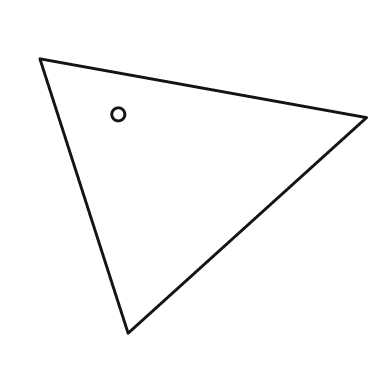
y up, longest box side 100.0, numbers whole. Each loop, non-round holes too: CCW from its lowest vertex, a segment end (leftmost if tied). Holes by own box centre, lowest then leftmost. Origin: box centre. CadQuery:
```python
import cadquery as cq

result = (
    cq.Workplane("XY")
    .moveTo(-23.0, -42.0)
    .lineTo(50.0, 24.0)
    .lineTo(-50.0, 42.0)
    .close()
    .moveTo(-26.0, 25.0)
    .circle(2.0)
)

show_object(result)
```